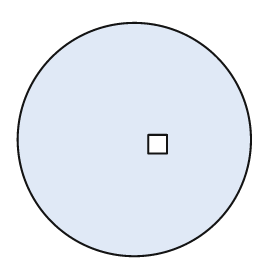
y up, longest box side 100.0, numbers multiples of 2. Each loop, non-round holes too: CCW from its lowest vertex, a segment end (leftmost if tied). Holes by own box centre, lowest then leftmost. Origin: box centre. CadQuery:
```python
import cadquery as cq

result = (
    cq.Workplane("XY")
    .moveTo(0.0, 0.0)
    .circle(50.0)
    .moveTo(6.0, -6.0)
    .lineTo(14.0, -6.0)
    .lineTo(14.0, 2.0)
    .lineTo(6.0, 2.0)
    .close()
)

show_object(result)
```